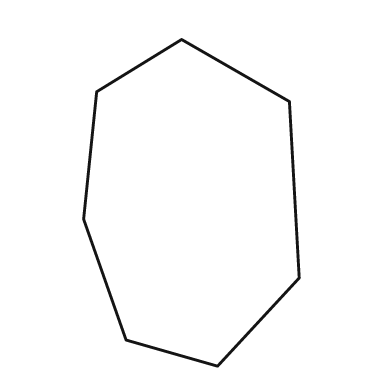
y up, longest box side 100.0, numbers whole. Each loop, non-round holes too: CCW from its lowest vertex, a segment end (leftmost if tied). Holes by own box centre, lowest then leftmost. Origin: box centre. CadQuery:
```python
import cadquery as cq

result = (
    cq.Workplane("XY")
    .moveTo(8.0, -50.0)
    .lineTo(33.0, -23.0)
    .lineTo(30.0, 31.0)
    .lineTo(-3.0, 50.0)
    .lineTo(-29.0, 34.0)
    .lineTo(-33.0, -5.0)
    .lineTo(-20.0, -42.0)
    .close()
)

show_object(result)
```